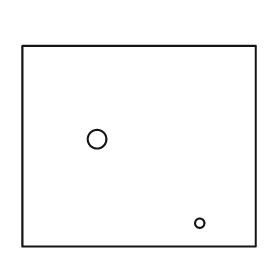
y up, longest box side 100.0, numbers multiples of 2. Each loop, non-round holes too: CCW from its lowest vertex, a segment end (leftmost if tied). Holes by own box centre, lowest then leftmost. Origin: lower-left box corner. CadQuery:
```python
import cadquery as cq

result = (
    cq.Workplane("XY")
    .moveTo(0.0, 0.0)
    .lineTo(100.0, 0.0)
    .lineTo(100.0, 86.0)
    .lineTo(0.0, 86.0)
    .close()
    .moveTo(76.0, 10.0)
    .circle(2.0)
    .moveTo(32.0, 46.0)
    .circle(4.0)
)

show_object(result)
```